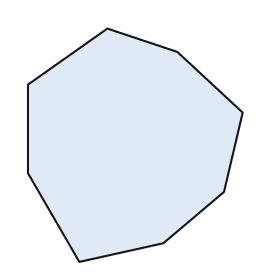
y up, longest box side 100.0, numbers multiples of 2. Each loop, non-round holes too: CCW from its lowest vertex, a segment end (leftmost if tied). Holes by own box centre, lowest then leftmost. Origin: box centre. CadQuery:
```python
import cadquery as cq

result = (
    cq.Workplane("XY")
    .moveTo(-24.0, -50.0)
    .lineTo(12.0, -42.0)
    .lineTo(38.0, -20.0)
    .lineTo(46.0, 14.0)
    .lineTo(18.0, 40.0)
    .lineTo(-12.0, 50.0)
    .lineTo(-46.0, 26.0)
    .lineTo(-46.0, -12.0)
    .close()
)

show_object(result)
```